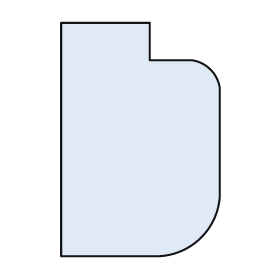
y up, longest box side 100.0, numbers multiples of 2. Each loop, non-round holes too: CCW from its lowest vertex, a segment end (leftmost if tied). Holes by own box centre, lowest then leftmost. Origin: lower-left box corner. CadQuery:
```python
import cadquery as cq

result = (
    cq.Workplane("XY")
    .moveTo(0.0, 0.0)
    .lineTo(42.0, 0.0)
    .threePointArc((60.0, 8.0), (68.0, 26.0))
    .lineTo(68.0, 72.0)
    .threePointArc((64.0, 80.0), (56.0, 84.0))
    .lineTo(38.0, 84.0)
    .lineTo(38.0, 100.0)
    .lineTo(0.0, 100.0)
    .close()
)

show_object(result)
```